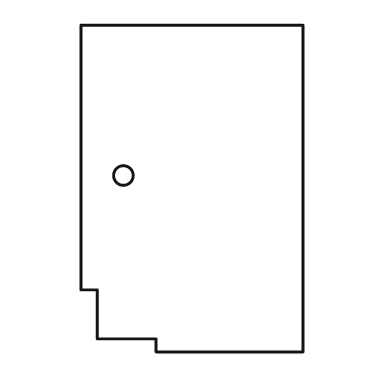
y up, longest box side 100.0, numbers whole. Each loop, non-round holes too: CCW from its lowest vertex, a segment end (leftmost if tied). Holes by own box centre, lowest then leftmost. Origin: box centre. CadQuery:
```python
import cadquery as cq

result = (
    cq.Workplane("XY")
    .moveTo(-11.0, -50.0)
    .lineTo(34.0, -50.0)
    .lineTo(34.0, 50.0)
    .lineTo(-34.0, 50.0)
    .lineTo(-34.0, -31.0)
    .lineTo(-29.0, -31.0)
    .lineTo(-29.0, -46.0)
    .lineTo(-11.0, -46.0)
    .close()
    .moveTo(-21.0, 4.0)
    .circle(3.0)
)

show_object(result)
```